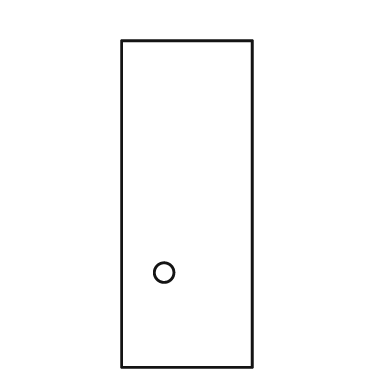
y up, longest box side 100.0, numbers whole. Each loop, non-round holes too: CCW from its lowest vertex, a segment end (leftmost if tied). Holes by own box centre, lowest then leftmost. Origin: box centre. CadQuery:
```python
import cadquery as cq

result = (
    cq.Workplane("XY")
    .moveTo(-20.0, -50.0)
    .lineTo(20.0, -50.0)
    .lineTo(20.0, 50.0)
    .lineTo(-20.0, 50.0)
    .close()
    .moveTo(-7.0, -21.0)
    .circle(3.0)
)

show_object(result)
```